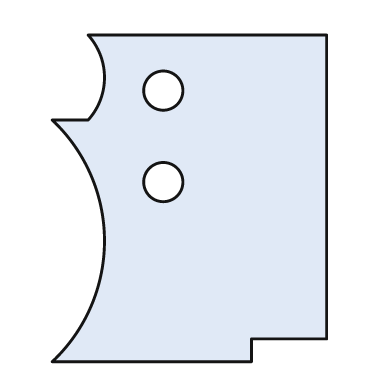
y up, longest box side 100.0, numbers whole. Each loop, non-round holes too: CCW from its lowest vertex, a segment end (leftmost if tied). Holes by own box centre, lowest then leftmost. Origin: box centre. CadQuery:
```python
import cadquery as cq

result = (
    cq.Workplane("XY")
    .moveTo(-42.0, -50.0)
    .lineTo(19.0, -50.0)
    .lineTo(19.0, -43.0)
    .lineTo(42.0, -43.0)
    .lineTo(42.0, 50.0)
    .lineTo(-31.0, 50.0)
    .threePointArc((-26.0, 37.0), (-31.0, 24.0))
    .lineTo(-42.0, 24.0)
    .threePointArc((-26.0, -13.0), (-42.0, -50.0))
    .close()
    .moveTo(-8.0, 5.0)
    .circle(6.0)
    .moveTo(-8.0, 33.0)
    .circle(6.0)
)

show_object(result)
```